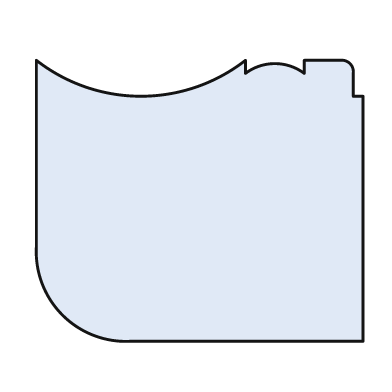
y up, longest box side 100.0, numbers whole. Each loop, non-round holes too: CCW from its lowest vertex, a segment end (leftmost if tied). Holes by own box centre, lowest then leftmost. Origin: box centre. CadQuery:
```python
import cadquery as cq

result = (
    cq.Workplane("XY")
    .moveTo(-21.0, -43.0)
    .lineTo(50.0, -43.0)
    .lineTo(50.0, 32.0)
    .lineTo(47.0, 32.0)
    .lineTo(47.0, 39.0)
    .threePointArc((46.0, 42.0), (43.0, 43.0))
    .lineTo(32.0, 43.0)
    .lineTo(32.0, 39.0)
    .threePointArc((23.0, 42.0), (14.0, 39.0))
    .lineTo(14.0, 43.0)
    .threePointArc((-18.0, 32.0), (-50.0, 43.0))
    .lineTo(-50.0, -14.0)
    .threePointArc((-42.0, -35.0), (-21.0, -43.0))
    .close()
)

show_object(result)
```